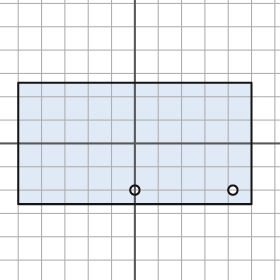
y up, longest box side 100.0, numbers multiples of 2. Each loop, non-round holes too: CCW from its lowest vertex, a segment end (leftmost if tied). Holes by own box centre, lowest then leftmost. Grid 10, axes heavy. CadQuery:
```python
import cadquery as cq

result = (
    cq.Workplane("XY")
    .moveTo(-50.0, -26.0)
    .lineTo(50.0, -26.0)
    .lineTo(50.0, 26.0)
    .lineTo(-50.0, 26.0)
    .close()
    .moveTo(0.0, -20.0)
    .circle(2.0)
    .moveTo(42.0, -20.0)
    .circle(2.0)
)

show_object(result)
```